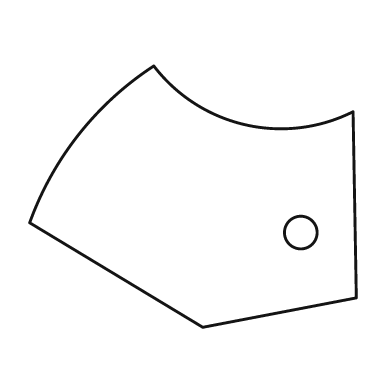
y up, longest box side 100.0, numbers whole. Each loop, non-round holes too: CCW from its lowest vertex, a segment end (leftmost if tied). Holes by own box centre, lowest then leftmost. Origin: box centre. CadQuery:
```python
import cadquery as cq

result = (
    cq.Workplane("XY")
    .moveTo(3.0, -40.0)
    .lineTo(50.0, -31.0)
    .lineTo(49.0, 26.0)
    .threePointArc((16.0, 22.0), (-12.0, 40.0))
    .threePointArc((-35.0, 19.0), (-50.0, -8.0))
    .close()
    .moveTo(33.0, -11.0)
    .circle(5.0)
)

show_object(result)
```